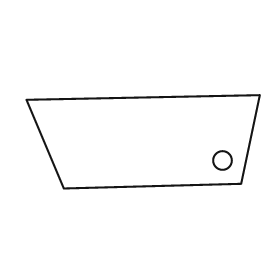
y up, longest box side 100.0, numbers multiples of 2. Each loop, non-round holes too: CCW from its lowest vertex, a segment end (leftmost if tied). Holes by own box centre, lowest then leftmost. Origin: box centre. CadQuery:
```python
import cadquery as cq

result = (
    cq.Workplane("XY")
    .moveTo(-34.0, -20.0)
    .lineTo(42.0, -18.0)
    .lineTo(50.0, 20.0)
    .lineTo(-50.0, 18.0)
    .close()
    .moveTo(34.0, -8.0)
    .circle(4.0)
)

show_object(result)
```